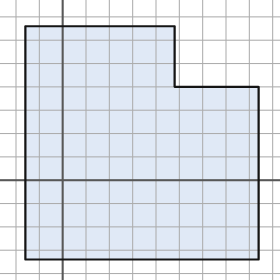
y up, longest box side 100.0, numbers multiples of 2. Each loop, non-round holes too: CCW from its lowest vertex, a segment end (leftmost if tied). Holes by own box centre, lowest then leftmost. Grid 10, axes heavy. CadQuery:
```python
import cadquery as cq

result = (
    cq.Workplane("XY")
    .moveTo(-16.0, -34.0)
    .lineTo(84.0, -34.0)
    .lineTo(84.0, 40.0)
    .lineTo(48.0, 40.0)
    .lineTo(48.0, 66.0)
    .lineTo(-16.0, 66.0)
    .close()
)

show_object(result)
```